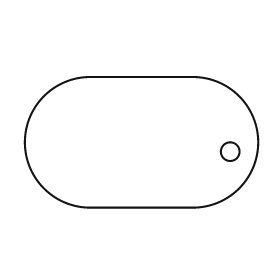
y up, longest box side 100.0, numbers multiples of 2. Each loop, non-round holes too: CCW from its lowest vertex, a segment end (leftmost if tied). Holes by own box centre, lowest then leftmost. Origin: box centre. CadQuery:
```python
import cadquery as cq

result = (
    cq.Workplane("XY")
    .moveTo(-22.0, -28.0)
    .lineTo(22.0, -28.0)
    .threePointArc((50.0, 0.0), (22.0, 28.0))
    .lineTo(-22.0, 28.0)
    .threePointArc((-50.0, 0.0), (-22.0, -28.0))
    .close()
    .moveTo(38.0, -4.0)
    .circle(4.0)
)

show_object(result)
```